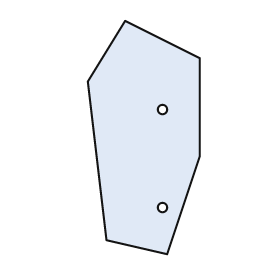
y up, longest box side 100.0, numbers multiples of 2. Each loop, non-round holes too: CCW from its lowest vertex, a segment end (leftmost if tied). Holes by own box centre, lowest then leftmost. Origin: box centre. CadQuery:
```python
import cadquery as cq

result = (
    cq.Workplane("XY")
    .moveTo(10.0, -50.0)
    .lineTo(24.0, -8.0)
    .lineTo(24.0, 34.0)
    .lineTo(-8.0, 50.0)
    .lineTo(-24.0, 24.0)
    .lineTo(-16.0, -44.0)
    .close()
    .moveTo(8.0, -30.0)
    .circle(2.0)
    .moveTo(8.0, 12.0)
    .circle(2.0)
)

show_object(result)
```